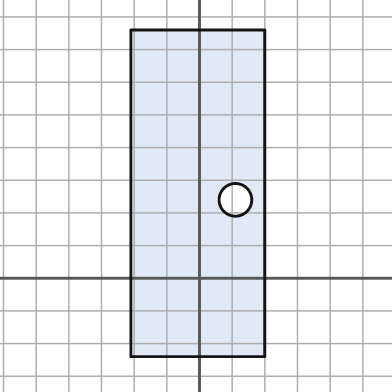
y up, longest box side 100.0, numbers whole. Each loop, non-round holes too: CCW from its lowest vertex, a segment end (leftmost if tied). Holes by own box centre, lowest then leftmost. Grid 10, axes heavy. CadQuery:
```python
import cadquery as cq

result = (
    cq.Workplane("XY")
    .moveTo(-21.0, -24.0)
    .lineTo(20.0, -24.0)
    .lineTo(20.0, 76.0)
    .lineTo(-21.0, 76.0)
    .close()
    .moveTo(11.0, 24.0)
    .circle(5.0)
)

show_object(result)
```